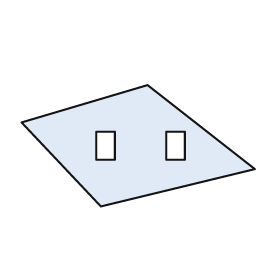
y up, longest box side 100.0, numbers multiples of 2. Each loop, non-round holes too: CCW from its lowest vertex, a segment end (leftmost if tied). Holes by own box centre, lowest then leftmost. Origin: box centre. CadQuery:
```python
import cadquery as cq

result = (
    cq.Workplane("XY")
    .moveTo(-16.0, -26.0)
    .lineTo(50.0, -10.0)
    .lineTo(4.0, 26.0)
    .lineTo(-50.0, 10.0)
    .close()
    .moveTo(-18.0, -6.0)
    .lineTo(-10.0, -6.0)
    .lineTo(-10.0, 6.0)
    .lineTo(-18.0, 6.0)
    .close()
    .moveTo(12.0, -6.0)
    .lineTo(20.0, -6.0)
    .lineTo(20.0, 6.0)
    .lineTo(12.0, 6.0)
    .close()
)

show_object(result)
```